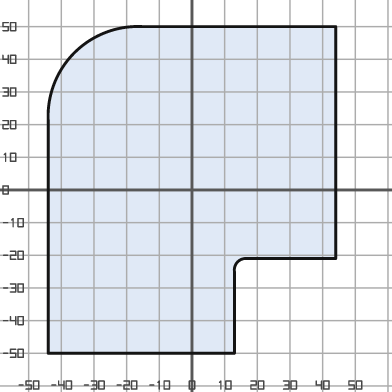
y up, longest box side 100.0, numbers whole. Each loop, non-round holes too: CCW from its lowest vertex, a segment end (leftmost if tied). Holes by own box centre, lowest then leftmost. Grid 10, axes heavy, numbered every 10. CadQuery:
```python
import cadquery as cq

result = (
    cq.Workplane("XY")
    .moveTo(-44.0, -50.0)
    .lineTo(13.0, -50.0)
    .lineTo(13.0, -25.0)
    .threePointArc((14.0, -22.0), (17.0, -21.0))
    .lineTo(44.0, -21.0)
    .lineTo(44.0, 50.0)
    .lineTo(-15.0, 50.0)
    .threePointArc((-36.0, 42.0), (-44.0, 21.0))
    .close()
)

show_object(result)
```